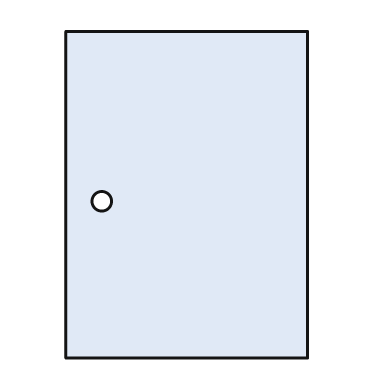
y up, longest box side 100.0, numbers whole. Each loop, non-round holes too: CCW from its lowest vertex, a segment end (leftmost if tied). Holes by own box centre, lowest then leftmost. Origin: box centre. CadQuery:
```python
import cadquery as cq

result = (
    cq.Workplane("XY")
    .moveTo(-37.0, -50.0)
    .lineTo(37.0, -50.0)
    .lineTo(37.0, 50.0)
    .lineTo(-37.0, 50.0)
    .close()
    .moveTo(-26.0, -2.0)
    .circle(3.0)
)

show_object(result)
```